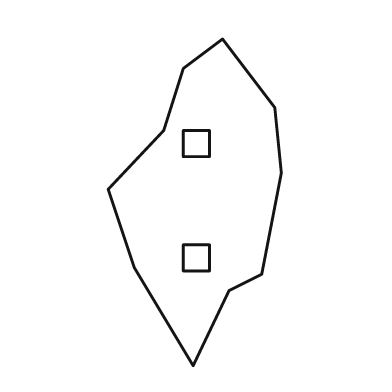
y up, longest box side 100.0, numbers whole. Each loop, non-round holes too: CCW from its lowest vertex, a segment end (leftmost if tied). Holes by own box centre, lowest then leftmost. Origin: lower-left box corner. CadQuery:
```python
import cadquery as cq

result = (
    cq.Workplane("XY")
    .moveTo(26.0, 0.0)
    .lineTo(37.0, 23.0)
    .lineTo(47.0, 28.0)
    .lineTo(53.0, 59.0)
    .lineTo(51.0, 79.0)
    .lineTo(35.0, 100.0)
    .lineTo(23.0, 91.0)
    .lineTo(17.0, 72.0)
    .lineTo(0.0, 54.0)
    .lineTo(8.0, 30.0)
    .close()
    .moveTo(23.0, 29.0)
    .lineTo(31.0, 29.0)
    .lineTo(31.0, 37.0)
    .lineTo(23.0, 37.0)
    .close()
    .moveTo(23.0, 64.0)
    .lineTo(31.0, 64.0)
    .lineTo(31.0, 72.0)
    .lineTo(23.0, 72.0)
    .close()
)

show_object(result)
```